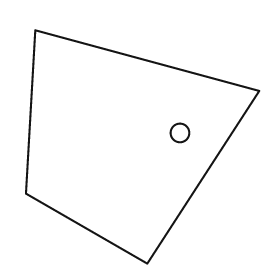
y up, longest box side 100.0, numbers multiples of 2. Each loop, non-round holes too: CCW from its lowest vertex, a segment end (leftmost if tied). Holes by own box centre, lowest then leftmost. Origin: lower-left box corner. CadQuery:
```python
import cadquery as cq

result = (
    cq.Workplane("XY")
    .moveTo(52.0, 0.0)
    .lineTo(100.0, 74.0)
    .lineTo(4.0, 100.0)
    .lineTo(0.0, 30.0)
    .close()
    .moveTo(66.0, 56.0)
    .circle(4.0)
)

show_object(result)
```